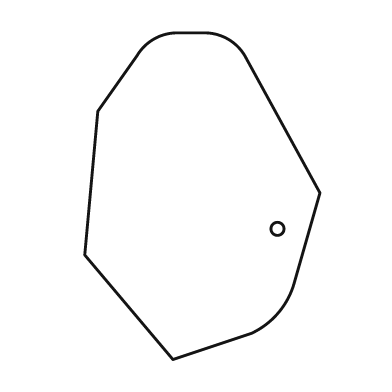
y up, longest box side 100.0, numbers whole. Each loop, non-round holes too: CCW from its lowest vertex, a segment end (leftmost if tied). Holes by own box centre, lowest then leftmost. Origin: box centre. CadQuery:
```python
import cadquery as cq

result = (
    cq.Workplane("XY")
    .moveTo(-9.0, -50.0)
    .lineTo(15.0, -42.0)
    .threePointArc((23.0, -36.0), (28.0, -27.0))
    .lineTo(36.0, 1.0)
    .lineTo(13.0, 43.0)
    .threePointArc((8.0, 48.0), (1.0, 50.0))
    .lineTo(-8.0, 50.0)
    .threePointArc((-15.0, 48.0), (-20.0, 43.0))
    .lineTo(-32.0, 26.0)
    .lineTo(-36.0, -18.0)
    .close()
    .moveTo(23.0, -10.0)
    .circle(2.0)
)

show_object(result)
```